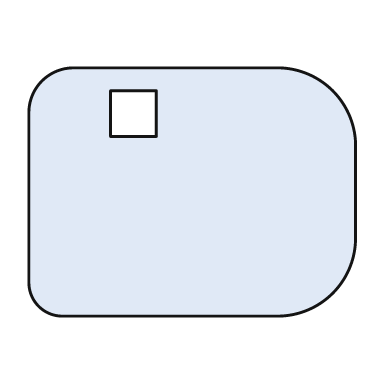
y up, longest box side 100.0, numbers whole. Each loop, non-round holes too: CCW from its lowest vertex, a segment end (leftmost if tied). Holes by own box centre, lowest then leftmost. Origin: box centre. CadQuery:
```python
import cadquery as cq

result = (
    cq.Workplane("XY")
    .moveTo(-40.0, -38.0)
    .lineTo(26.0, -38.0)
    .threePointArc((43.0, -31.0), (50.0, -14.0))
    .lineTo(50.0, 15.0)
    .threePointArc((43.0, 31.0), (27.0, 38.0))
    .lineTo(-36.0, 38.0)
    .threePointArc((-46.0, 34.0), (-50.0, 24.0))
    .lineTo(-50.0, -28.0)
    .threePointArc((-47.0, -35.0), (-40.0, -38.0))
    .close()
    .moveTo(-25.0, 17.0)
    .lineTo(-11.0, 17.0)
    .lineTo(-11.0, 31.0)
    .lineTo(-25.0, 31.0)
    .close()
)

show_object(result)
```